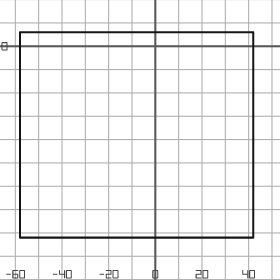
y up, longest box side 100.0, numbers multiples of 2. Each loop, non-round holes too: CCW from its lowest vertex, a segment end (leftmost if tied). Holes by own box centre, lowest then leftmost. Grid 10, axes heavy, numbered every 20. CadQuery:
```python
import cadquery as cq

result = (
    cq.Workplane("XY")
    .moveTo(-58.0, -82.0)
    .lineTo(42.0, -82.0)
    .lineTo(42.0, 6.0)
    .lineTo(-58.0, 6.0)
    .close()
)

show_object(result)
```